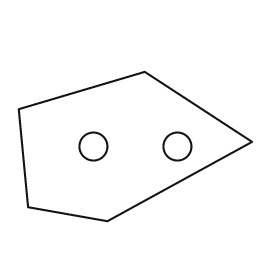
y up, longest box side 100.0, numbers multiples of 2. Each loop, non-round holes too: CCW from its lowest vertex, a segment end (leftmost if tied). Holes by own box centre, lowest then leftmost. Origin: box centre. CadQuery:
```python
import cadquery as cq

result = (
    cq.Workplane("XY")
    .moveTo(-12.0, -32.0)
    .lineTo(50.0, 2.0)
    .lineTo(4.0, 32.0)
    .lineTo(-50.0, 16.0)
    .lineTo(-46.0, -26.0)
    .close()
    .moveTo(-18.0, 0.0)
    .circle(6.0)
    .moveTo(18.0, 0.0)
    .circle(6.0)
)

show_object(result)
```